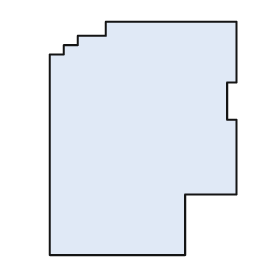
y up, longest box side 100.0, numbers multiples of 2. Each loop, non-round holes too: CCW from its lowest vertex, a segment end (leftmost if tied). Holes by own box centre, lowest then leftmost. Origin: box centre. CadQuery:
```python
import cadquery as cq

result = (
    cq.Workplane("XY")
    .moveTo(-40.0, -50.0)
    .lineTo(18.0, -50.0)
    .lineTo(18.0, -24.0)
    .lineTo(40.0, -24.0)
    .lineTo(40.0, 8.0)
    .lineTo(36.0, 8.0)
    .lineTo(36.0, 24.0)
    .lineTo(40.0, 24.0)
    .lineTo(40.0, 50.0)
    .lineTo(-16.0, 50.0)
    .lineTo(-16.0, 44.0)
    .lineTo(-28.0, 44.0)
    .lineTo(-28.0, 40.0)
    .lineTo(-34.0, 40.0)
    .lineTo(-34.0, 36.0)
    .lineTo(-40.0, 36.0)
    .close()
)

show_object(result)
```